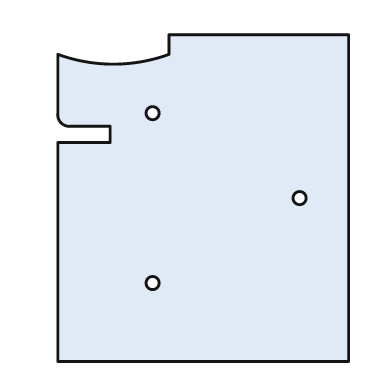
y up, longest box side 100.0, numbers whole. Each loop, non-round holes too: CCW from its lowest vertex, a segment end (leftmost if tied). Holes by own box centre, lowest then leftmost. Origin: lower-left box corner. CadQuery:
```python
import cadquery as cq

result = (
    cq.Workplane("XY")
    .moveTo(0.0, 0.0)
    .lineTo(89.0, 0.0)
    .lineTo(89.0, 100.0)
    .lineTo(34.0, 100.0)
    .lineTo(34.0, 94.0)
    .threePointArc((17.0, 91.0), (0.0, 94.0))
    .lineTo(0.0, 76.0)
    .threePointArc((1.0, 73.0), (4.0, 72.0))
    .lineTo(16.0, 72.0)
    .lineTo(16.0, 67.0)
    .lineTo(0.0, 67.0)
    .close()
    .moveTo(29.0, 24.0)
    .circle(2.0)
    .moveTo(74.0, 50.0)
    .circle(2.0)
    .moveTo(29.0, 76.0)
    .circle(2.0)
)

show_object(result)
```